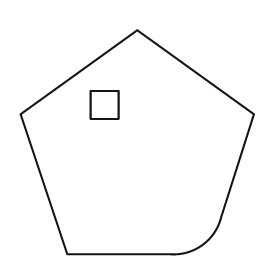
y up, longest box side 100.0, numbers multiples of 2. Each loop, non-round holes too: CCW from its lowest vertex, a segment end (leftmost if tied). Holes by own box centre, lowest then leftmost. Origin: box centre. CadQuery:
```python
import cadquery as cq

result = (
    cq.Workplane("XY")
    .moveTo(-30.0, -48.0)
    .lineTo(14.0, -48.0)
    .threePointArc((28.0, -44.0), (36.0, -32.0))
    .lineTo(50.0, 12.0)
    .lineTo(0.0, 48.0)
    .lineTo(-50.0, 12.0)
    .close()
    .moveTo(-20.0, 10.0)
    .lineTo(-8.0, 10.0)
    .lineTo(-8.0, 22.0)
    .lineTo(-20.0, 22.0)
    .close()
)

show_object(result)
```